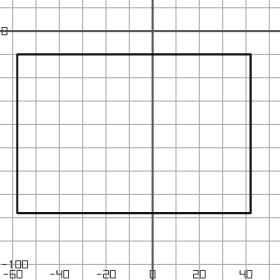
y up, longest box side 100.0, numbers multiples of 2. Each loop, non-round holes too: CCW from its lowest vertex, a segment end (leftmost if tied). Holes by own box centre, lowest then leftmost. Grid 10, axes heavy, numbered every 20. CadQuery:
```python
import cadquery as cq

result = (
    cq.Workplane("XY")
    .moveTo(-58.0, -78.0)
    .lineTo(42.0, -78.0)
    .lineTo(42.0, -10.0)
    .lineTo(-58.0, -10.0)
    .close()
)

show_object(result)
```